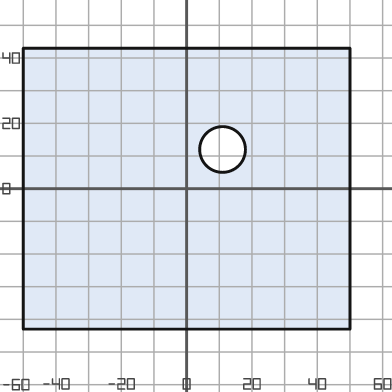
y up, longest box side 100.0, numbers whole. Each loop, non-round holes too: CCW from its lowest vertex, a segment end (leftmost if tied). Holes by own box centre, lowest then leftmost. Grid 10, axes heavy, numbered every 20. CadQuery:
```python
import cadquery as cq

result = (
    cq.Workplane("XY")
    .moveTo(-50.0, -43.0)
    .lineTo(50.0, -43.0)
    .lineTo(50.0, 43.0)
    .lineTo(-50.0, 43.0)
    .close()
    .moveTo(11.0, 12.0)
    .circle(7.0)
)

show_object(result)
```